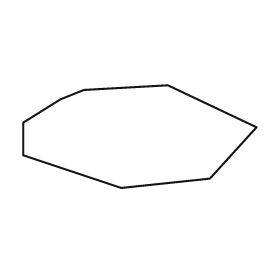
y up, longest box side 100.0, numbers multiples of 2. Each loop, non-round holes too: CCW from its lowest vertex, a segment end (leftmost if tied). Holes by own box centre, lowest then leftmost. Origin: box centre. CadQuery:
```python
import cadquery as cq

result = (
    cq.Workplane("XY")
    .moveTo(-8.0, -22.0)
    .lineTo(30.0, -18.0)
    .lineTo(50.0, 4.0)
    .lineTo(12.0, 22.0)
    .lineTo(-24.0, 20.0)
    .lineTo(-34.0, 16.0)
    .lineTo(-50.0, 6.0)
    .lineTo(-50.0, -8.0)
    .close()
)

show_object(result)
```